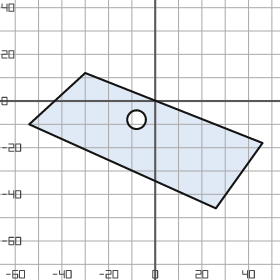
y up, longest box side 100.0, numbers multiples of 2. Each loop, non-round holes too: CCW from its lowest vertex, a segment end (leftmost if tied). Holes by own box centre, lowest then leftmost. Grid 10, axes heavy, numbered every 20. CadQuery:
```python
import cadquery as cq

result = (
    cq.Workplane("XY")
    .moveTo(26.0, -46.0)
    .lineTo(46.0, -18.0)
    .lineTo(-30.0, 12.0)
    .lineTo(-54.0, -10.0)
    .close()
    .moveTo(-8.0, -8.0)
    .circle(4.0)
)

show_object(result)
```